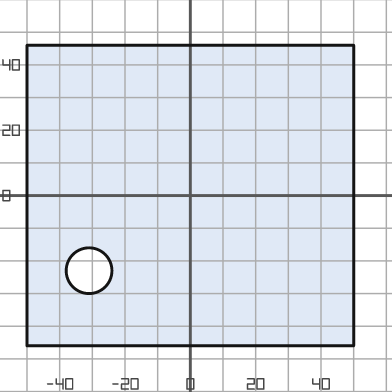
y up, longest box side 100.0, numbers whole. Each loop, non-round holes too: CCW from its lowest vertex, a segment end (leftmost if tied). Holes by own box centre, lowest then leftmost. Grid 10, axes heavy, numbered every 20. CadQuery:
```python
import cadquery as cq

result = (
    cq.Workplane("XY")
    .moveTo(-50.0, -46.0)
    .lineTo(50.0, -46.0)
    .lineTo(50.0, 46.0)
    .lineTo(-50.0, 46.0)
    .close()
    .moveTo(-31.0, -23.0)
    .circle(7.0)
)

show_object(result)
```